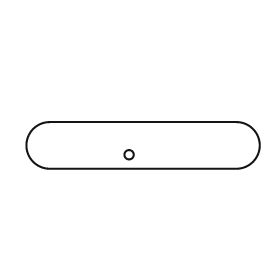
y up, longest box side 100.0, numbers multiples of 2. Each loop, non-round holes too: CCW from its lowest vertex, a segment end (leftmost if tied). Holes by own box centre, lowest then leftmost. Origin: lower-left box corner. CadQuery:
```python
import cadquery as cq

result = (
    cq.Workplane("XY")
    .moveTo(10.0, 0.0)
    .lineTo(90.0, 0.0)
    .threePointArc((100.0, 10.0), (90.0, 20.0))
    .lineTo(10.0, 20.0)
    .threePointArc((0.0, 10.0), (10.0, 0.0))
    .close()
    .moveTo(44.0, 6.0)
    .circle(2.0)
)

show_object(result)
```